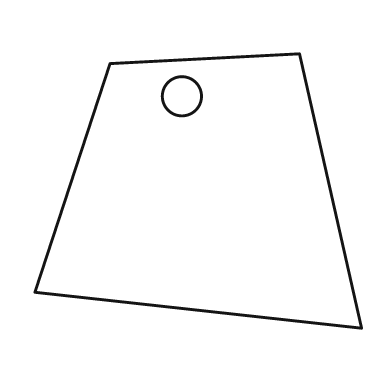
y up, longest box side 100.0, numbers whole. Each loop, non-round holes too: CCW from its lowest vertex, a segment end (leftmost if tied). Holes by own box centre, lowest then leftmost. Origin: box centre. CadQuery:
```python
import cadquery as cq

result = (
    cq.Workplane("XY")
    .moveTo(50.0, -42.0)
    .lineTo(31.0, 42.0)
    .lineTo(-27.0, 39.0)
    .lineTo(-50.0, -31.0)
    .close()
    .moveTo(-5.0, 29.0)
    .circle(6.0)
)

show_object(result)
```